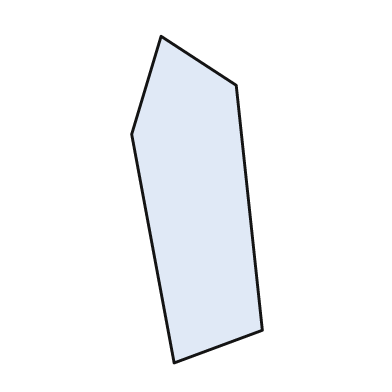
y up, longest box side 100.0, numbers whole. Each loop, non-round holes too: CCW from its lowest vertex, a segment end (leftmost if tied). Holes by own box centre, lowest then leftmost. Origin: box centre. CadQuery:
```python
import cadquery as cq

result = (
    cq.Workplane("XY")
    .moveTo(-7.0, -50.0)
    .lineTo(20.0, -40.0)
    .lineTo(12.0, 35.0)
    .lineTo(-11.0, 50.0)
    .lineTo(-20.0, 20.0)
    .close()
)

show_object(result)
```